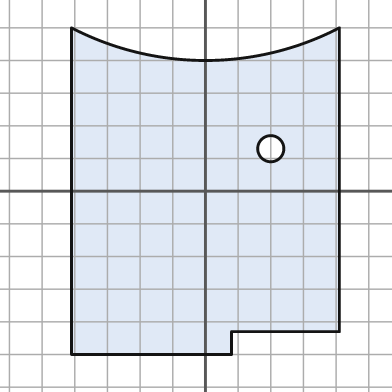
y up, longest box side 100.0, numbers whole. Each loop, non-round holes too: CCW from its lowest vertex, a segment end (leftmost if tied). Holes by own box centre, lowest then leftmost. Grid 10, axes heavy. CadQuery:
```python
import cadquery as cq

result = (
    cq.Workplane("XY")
    .moveTo(-41.0, -50.0)
    .lineTo(8.0, -50.0)
    .lineTo(8.0, -43.0)
    .lineTo(41.0, -43.0)
    .lineTo(41.0, 50.0)
    .threePointArc((0.0, 40.0), (-41.0, 50.0))
    .close()
    .moveTo(20.0, 13.0)
    .circle(4.0)
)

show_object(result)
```